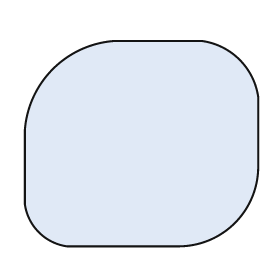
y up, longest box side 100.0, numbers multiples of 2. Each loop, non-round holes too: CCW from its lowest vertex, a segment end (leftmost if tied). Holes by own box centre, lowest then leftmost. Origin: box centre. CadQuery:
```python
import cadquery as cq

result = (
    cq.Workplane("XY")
    .moveTo(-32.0, -44.0)
    .lineTo(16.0, -44.0)
    .threePointArc((40.0, -34.0), (50.0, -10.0))
    .lineTo(50.0, 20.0)
    .threePointArc((42.0, 36.0), (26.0, 44.0))
    .lineTo(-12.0, 44.0)
    .threePointArc((-38.0, 32.0), (-50.0, 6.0))
    .lineTo(-50.0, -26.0)
    .threePointArc((-44.0, -38.0), (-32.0, -44.0))
    .close()
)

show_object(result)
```